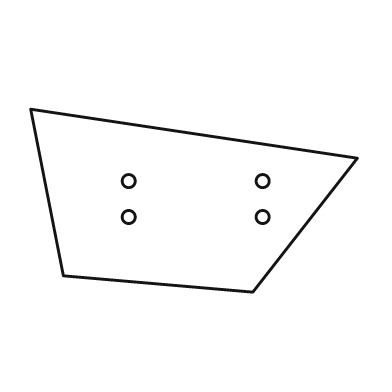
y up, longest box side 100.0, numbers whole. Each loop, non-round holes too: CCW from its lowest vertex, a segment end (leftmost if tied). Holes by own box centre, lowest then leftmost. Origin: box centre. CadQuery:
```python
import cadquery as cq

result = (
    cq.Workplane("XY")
    .moveTo(18.0, -28.0)
    .lineTo(50.0, 13.0)
    .lineTo(-50.0, 28.0)
    .lineTo(-40.0, -23.0)
    .close()
    .moveTo(-20.0, -5.0)
    .circle(2.0)
    .moveTo(21.0, -5.0)
    .circle(2.0)
    .moveTo(-20.0, 6.0)
    .circle(2.0)
    .moveTo(21.0, 6.0)
    .circle(2.0)
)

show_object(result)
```